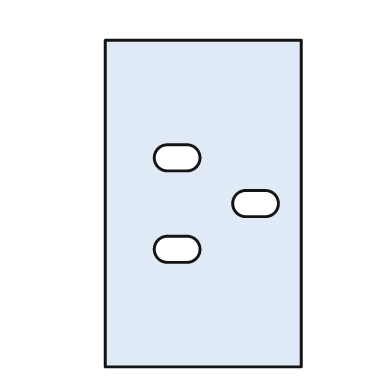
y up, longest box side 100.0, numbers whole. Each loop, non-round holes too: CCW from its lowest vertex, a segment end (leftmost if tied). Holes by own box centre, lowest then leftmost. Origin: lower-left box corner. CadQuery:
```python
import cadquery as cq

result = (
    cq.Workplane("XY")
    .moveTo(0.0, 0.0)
    .lineTo(60.0, 0.0)
    .lineTo(60.0, 100.0)
    .lineTo(0.0, 100.0)
    .close()
    .moveTo(19.0, 32.0)
    .lineTo(25.0, 32.0)
    .threePointArc((29.0, 36.0), (25.0, 40.0))
    .lineTo(19.0, 40.0)
    .threePointArc((15.0, 36.0), (19.0, 32.0))
    .close()
    .moveTo(43.0, 46.0)
    .lineTo(49.0, 46.0)
    .threePointArc((53.0, 50.0), (49.0, 54.0))
    .lineTo(43.0, 54.0)
    .threePointArc((39.0, 50.0), (43.0, 46.0))
    .close()
    .moveTo(19.0, 60.0)
    .lineTo(25.0, 60.0)
    .threePointArc((29.0, 64.0), (25.0, 68.0))
    .lineTo(19.0, 68.0)
    .threePointArc((15.0, 64.0), (19.0, 60.0))
    .close()
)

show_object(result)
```